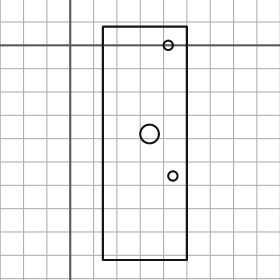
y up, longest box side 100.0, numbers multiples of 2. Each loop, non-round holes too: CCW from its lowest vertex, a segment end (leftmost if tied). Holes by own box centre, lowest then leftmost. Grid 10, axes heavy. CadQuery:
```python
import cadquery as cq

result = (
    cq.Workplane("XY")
    .moveTo(14.0, -92.0)
    .lineTo(50.0, -92.0)
    .lineTo(50.0, 8.0)
    .lineTo(14.0, 8.0)
    .close()
    .moveTo(44.0, -56.0)
    .circle(2.0)
    .moveTo(34.0, -38.0)
    .circle(4.0)
    .moveTo(42.0, 0.0)
    .circle(2.0)
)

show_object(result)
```